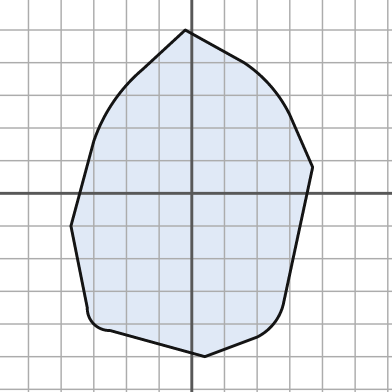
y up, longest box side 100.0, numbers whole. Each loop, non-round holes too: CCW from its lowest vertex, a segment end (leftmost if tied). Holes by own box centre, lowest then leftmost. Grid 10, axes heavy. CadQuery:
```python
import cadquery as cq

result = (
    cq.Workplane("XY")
    .moveTo(4.0, -50.0)
    .lineTo(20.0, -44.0)
    .threePointArc((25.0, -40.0), (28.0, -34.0))
    .lineTo(37.0, 8.0)
    .lineTo(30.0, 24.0)
    .threePointArc((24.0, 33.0), (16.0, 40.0))
    .lineTo(-2.0, 50.0)
    .lineTo(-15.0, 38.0)
    .threePointArc((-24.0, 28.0), (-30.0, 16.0))
    .lineTo(-37.0, -10.0)
    .lineTo(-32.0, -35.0)
    .threePointArc((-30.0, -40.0), (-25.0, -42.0))
    .close()
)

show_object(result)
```